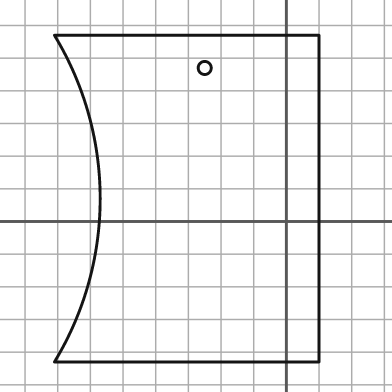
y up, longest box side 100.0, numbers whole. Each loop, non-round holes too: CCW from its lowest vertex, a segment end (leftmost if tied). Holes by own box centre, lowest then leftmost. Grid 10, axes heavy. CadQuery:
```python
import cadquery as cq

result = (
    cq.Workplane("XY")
    .moveTo(-71.0, -43.0)
    .lineTo(10.0, -43.0)
    .lineTo(10.0, 57.0)
    .lineTo(-71.0, 57.0)
    .threePointArc((-57.0, 7.0), (-71.0, -43.0))
    .close()
    .moveTo(-25.0, 47.0)
    .circle(2.0)
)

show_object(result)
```